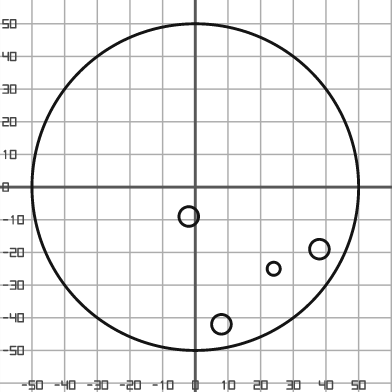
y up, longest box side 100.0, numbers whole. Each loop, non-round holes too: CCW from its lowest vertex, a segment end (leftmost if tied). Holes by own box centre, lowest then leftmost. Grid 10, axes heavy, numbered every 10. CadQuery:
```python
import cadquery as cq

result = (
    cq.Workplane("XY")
    .moveTo(0.0, 0.0)
    .circle(50.0)
    .moveTo(8.0, -42.0)
    .circle(3.0)
    .moveTo(24.0, -25.0)
    .circle(2.0)
    .moveTo(38.0, -19.0)
    .circle(3.0)
    .moveTo(-2.0, -9.0)
    .circle(3.0)
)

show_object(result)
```